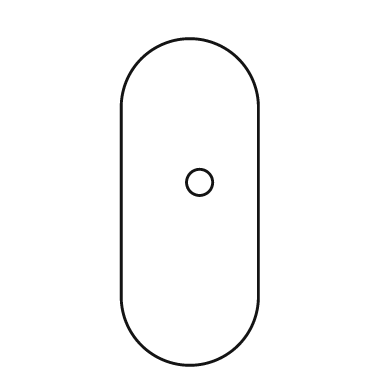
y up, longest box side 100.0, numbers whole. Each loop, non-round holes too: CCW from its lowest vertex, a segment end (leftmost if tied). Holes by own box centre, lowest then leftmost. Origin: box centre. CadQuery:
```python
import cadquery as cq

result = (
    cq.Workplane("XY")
    .moveTo(-21.0, -29.0)
    .threePointArc((0.0, -50.0), (21.0, -29.0))
    .lineTo(21.0, 29.0)
    .threePointArc((0.0, 50.0), (-21.0, 29.0))
    .close()
    .moveTo(3.0, 6.0)
    .circle(4.0)
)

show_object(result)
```